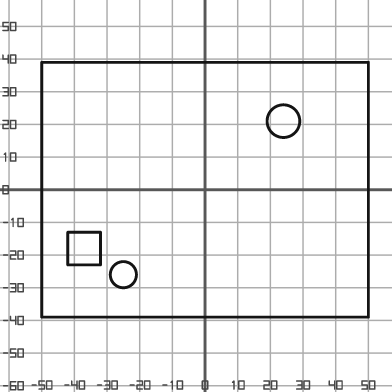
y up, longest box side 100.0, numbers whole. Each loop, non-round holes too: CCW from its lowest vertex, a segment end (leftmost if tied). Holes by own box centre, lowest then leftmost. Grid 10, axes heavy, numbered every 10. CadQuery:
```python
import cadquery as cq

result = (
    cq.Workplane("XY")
    .moveTo(-50.0, -39.0)
    .lineTo(50.0, -39.0)
    .lineTo(50.0, 39.0)
    .lineTo(-50.0, 39.0)
    .close()
    .moveTo(-25.0, -26.0)
    .circle(4.0)
    .moveTo(-42.0, -23.0)
    .lineTo(-32.0, -23.0)
    .lineTo(-32.0, -13.0)
    .lineTo(-42.0, -13.0)
    .close()
    .moveTo(24.0, 21.0)
    .circle(5.0)
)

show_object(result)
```